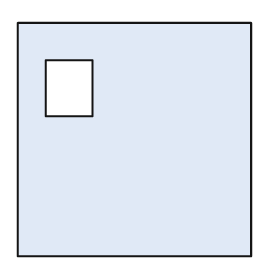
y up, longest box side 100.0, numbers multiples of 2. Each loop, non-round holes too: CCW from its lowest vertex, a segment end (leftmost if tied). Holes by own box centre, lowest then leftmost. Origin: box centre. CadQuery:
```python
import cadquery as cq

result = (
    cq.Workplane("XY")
    .moveTo(-50.0, -50.0)
    .lineTo(50.0, -50.0)
    .lineTo(50.0, 50.0)
    .lineTo(-50.0, 50.0)
    .close()
    .moveTo(-38.0, 10.0)
    .lineTo(-18.0, 10.0)
    .lineTo(-18.0, 34.0)
    .lineTo(-38.0, 34.0)
    .close()
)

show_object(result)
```